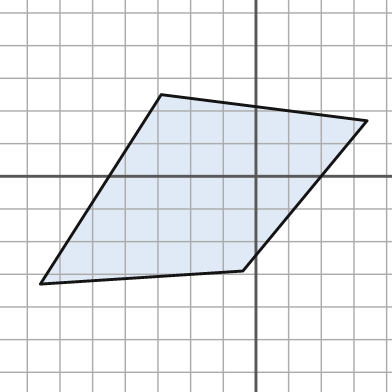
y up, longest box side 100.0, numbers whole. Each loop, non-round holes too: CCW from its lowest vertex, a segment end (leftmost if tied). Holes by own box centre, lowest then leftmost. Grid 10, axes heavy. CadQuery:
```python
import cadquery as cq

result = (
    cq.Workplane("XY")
    .moveTo(-66.0, -33.0)
    .lineTo(-4.0, -29.0)
    .lineTo(34.0, 17.0)
    .lineTo(-29.0, 25.0)
    .close()
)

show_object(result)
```